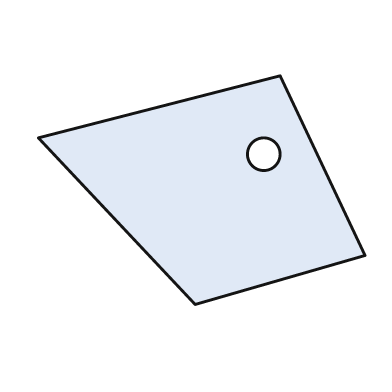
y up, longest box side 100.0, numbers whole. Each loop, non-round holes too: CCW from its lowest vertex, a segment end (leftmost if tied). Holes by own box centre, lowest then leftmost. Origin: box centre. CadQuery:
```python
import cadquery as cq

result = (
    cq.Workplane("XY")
    .moveTo(-2.0, -35.0)
    .lineTo(50.0, -20.0)
    .lineTo(24.0, 35.0)
    .lineTo(-50.0, 16.0)
    .close()
    .moveTo(19.0, 11.0)
    .circle(5.0)
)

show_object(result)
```